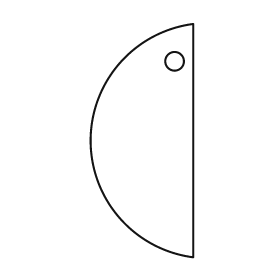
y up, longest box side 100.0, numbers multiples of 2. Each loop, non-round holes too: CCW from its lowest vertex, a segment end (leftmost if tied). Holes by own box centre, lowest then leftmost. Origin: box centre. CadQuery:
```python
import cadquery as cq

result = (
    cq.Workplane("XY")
    .moveTo(22.0, -50.0)
    .lineTo(22.0, 50.0)
    .threePointArc((-22.0, 0.0), (22.0, -50.0))
    .close()
    .moveTo(14.0, 34.0)
    .circle(4.0)
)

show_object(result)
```